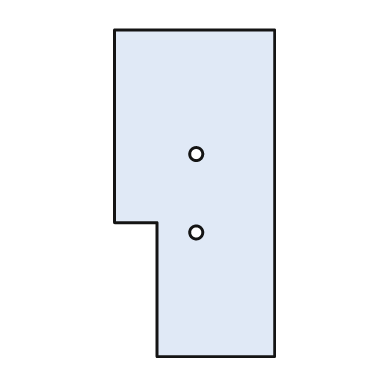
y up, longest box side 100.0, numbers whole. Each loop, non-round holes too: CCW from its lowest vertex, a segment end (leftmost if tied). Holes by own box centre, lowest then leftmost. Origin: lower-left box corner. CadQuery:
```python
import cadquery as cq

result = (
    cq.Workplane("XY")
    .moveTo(13.0, 0.0)
    .lineTo(49.0, 0.0)
    .lineTo(49.0, 100.0)
    .lineTo(0.0, 100.0)
    .lineTo(0.0, 41.0)
    .lineTo(13.0, 41.0)
    .close()
    .moveTo(25.0, 38.0)
    .circle(2.0)
    .moveTo(25.0, 62.0)
    .circle(2.0)
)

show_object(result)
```